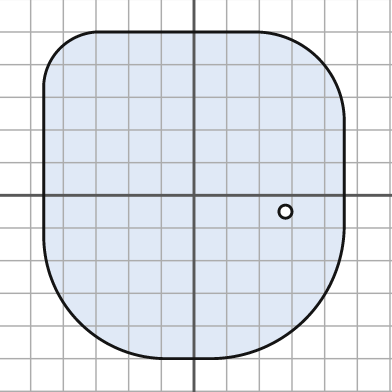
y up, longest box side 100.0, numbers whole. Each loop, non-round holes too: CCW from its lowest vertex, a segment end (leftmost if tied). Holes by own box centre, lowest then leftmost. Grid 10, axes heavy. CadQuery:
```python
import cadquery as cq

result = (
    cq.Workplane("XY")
    .moveTo(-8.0, -50.0)
    .lineTo(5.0, -50.0)
    .threePointArc((34.0, -38.0), (46.0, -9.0))
    .lineTo(46.0, 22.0)
    .threePointArc((38.0, 42.0), (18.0, 50.0))
    .lineTo(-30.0, 50.0)
    .threePointArc((-41.0, 45.0), (-46.0, 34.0))
    .lineTo(-46.0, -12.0)
    .threePointArc((-35.0, -39.0), (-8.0, -50.0))
    .close()
    .moveTo(28.0, -5.0)
    .circle(2.0)
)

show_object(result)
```